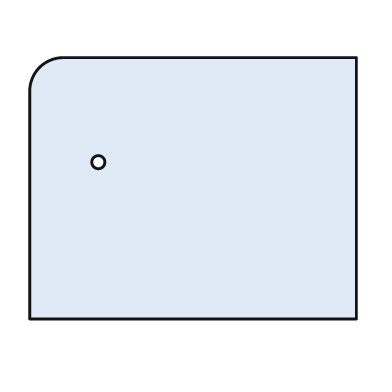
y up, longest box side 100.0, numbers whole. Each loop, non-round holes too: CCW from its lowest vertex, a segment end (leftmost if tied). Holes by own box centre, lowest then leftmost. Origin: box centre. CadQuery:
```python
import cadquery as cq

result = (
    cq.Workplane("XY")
    .moveTo(-50.0, -40.0)
    .lineTo(50.0, -40.0)
    .lineTo(50.0, 40.0)
    .lineTo(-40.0, 40.0)
    .threePointArc((-47.0, 37.0), (-50.0, 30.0))
    .close()
    .moveTo(-29.0, 8.0)
    .circle(2.0)
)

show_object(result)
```